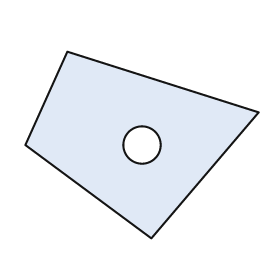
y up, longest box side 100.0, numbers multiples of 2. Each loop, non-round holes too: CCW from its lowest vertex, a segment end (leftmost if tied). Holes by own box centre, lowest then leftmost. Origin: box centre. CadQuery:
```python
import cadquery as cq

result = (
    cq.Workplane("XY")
    .moveTo(4.0, -40.0)
    .lineTo(50.0, 14.0)
    .lineTo(-32.0, 40.0)
    .lineTo(-50.0, 0.0)
    .close()
    .moveTo(0.0, 0.0)
    .circle(8.0)
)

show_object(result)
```